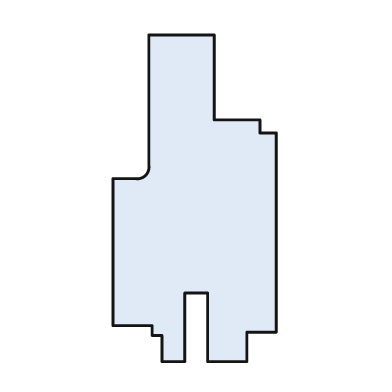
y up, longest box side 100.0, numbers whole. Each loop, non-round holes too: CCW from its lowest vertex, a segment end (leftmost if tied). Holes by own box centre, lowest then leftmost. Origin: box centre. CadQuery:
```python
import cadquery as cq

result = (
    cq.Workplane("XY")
    .moveTo(-10.0, -50.0)
    .lineTo(-3.0, -50.0)
    .lineTo(-3.0, -29.0)
    .lineTo(4.0, -29.0)
    .lineTo(4.0, -50.0)
    .lineTo(16.0, -50.0)
    .lineTo(16.0, -41.0)
    .lineTo(25.0, -41.0)
    .lineTo(25.0, 20.0)
    .lineTo(20.0, 20.0)
    .lineTo(20.0, 24.0)
    .lineTo(6.0, 24.0)
    .lineTo(6.0, 50.0)
    .lineTo(-14.0, 50.0)
    .lineTo(-14.0, 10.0)
    .threePointArc((-15.0, 7.0), (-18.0, 6.0))
    .lineTo(-25.0, 6.0)
    .lineTo(-25.0, -39.0)
    .lineTo(-13.0, -39.0)
    .lineTo(-13.0, -42.0)
    .lineTo(-10.0, -42.0)
    .close()
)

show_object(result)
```